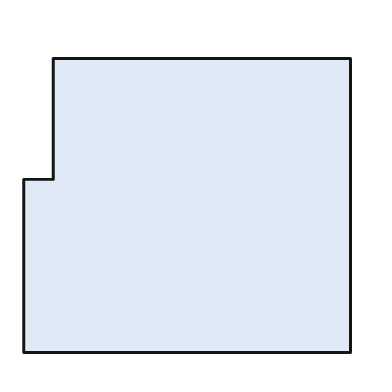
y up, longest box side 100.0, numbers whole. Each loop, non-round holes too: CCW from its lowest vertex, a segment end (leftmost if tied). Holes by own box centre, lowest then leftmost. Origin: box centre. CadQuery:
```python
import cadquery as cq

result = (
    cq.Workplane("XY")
    .moveTo(-50.0, -45.0)
    .lineTo(50.0, -45.0)
    .lineTo(50.0, 45.0)
    .lineTo(-41.0, 45.0)
    .lineTo(-41.0, 8.0)
    .lineTo(-50.0, 8.0)
    .close()
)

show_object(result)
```